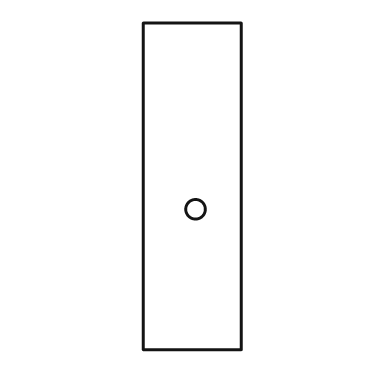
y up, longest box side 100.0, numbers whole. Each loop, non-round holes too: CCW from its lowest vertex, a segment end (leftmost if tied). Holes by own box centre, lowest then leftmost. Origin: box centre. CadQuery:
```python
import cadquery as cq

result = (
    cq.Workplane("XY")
    .moveTo(-15.0, -50.0)
    .lineTo(15.0, -50.0)
    .lineTo(15.0, 50.0)
    .lineTo(-15.0, 50.0)
    .close()
    .moveTo(1.0, -7.0)
    .circle(3.0)
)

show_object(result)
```